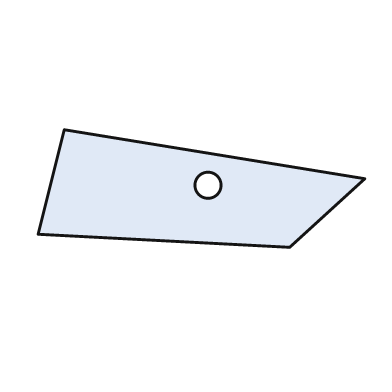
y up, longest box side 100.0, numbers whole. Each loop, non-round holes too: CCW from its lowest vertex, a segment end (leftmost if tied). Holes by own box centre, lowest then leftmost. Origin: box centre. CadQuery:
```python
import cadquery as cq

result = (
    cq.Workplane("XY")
    .moveTo(27.0, -18.0)
    .lineTo(50.0, 3.0)
    .lineTo(-42.0, 18.0)
    .lineTo(-50.0, -14.0)
    .close()
    .moveTo(2.0, 1.0)
    .circle(4.0)
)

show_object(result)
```